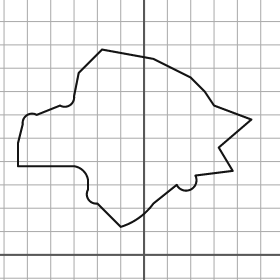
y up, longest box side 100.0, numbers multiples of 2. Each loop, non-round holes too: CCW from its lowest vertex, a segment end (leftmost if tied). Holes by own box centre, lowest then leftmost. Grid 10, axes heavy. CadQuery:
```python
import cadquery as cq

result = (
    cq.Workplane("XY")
    .moveTo(-10.0, 12.0)
    .threePointArc((-2.0, 16.0), (4.0, 22.0))
    .lineTo(14.0, 30.0)
    .threePointArc((20.0, 28.0), (22.0, 34.0))
    .lineTo(38.0, 36.0)
    .lineTo(32.0, 46.0)
    .lineTo(46.0, 58.0)
    .lineTo(30.0, 64.0)
    .lineTo(26.0, 70.0)
    .lineTo(20.0, 76.0)
    .lineTo(4.0, 84.0)
    .lineTo(-18.0, 88.0)
    .lineTo(-28.0, 78.0)
    .lineTo(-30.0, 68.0)
    .threePointArc((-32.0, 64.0), (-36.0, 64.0))
    .lineTo(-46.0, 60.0)
    .threePointArc((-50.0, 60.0), (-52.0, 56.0))
    .lineTo(-54.0, 48.0)
    .lineTo(-54.0, 38.0)
    .lineTo(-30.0, 38.0)
    .threePointArc((-26.0, 36.0), (-24.0, 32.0))
    .lineTo(-24.0, 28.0)
    .threePointArc((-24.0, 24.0), (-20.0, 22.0))
    .close()
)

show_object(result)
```